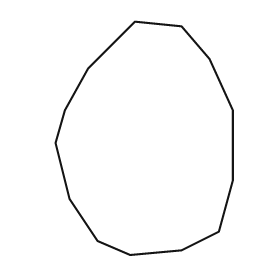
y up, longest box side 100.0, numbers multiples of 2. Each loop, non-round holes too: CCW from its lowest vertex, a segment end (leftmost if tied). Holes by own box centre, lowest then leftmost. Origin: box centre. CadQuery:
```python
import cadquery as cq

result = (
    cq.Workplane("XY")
    .moveTo(-6.0, -50.0)
    .lineTo(16.0, -48.0)
    .lineTo(32.0, -40.0)
    .lineTo(38.0, -18.0)
    .lineTo(38.0, 12.0)
    .lineTo(28.0, 34.0)
    .lineTo(16.0, 48.0)
    .lineTo(-4.0, 50.0)
    .lineTo(-24.0, 30.0)
    .lineTo(-34.0, 12.0)
    .lineTo(-38.0, -2.0)
    .lineTo(-32.0, -26.0)
    .lineTo(-20.0, -44.0)
    .close()
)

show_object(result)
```